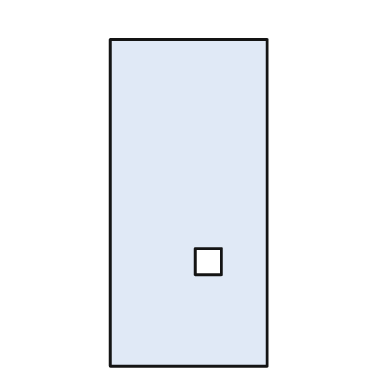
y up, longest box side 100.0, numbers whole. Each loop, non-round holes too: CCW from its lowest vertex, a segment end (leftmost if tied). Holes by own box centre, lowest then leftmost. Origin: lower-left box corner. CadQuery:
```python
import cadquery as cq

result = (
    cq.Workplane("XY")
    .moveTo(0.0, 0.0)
    .lineTo(48.0, 0.0)
    .lineTo(48.0, 100.0)
    .lineTo(0.0, 100.0)
    .close()
    .moveTo(26.0, 28.0)
    .lineTo(34.0, 28.0)
    .lineTo(34.0, 36.0)
    .lineTo(26.0, 36.0)
    .close()
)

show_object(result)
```